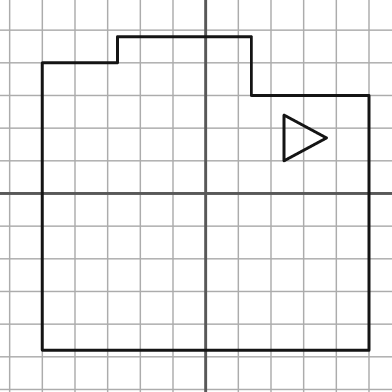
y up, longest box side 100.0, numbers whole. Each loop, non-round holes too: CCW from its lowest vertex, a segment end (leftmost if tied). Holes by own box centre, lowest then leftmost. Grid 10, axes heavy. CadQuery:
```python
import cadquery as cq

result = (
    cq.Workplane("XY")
    .moveTo(-50.0, -48.0)
    .lineTo(50.0, -48.0)
    .lineTo(50.0, 30.0)
    .lineTo(14.0, 30.0)
    .lineTo(14.0, 48.0)
    .lineTo(-27.0, 48.0)
    .lineTo(-27.0, 40.0)
    .lineTo(-50.0, 40.0)
    .close()
    .moveTo(24.0, 10.0)
    .lineTo(37.0, 17.0)
    .lineTo(24.0, 24.0)
    .close()
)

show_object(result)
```